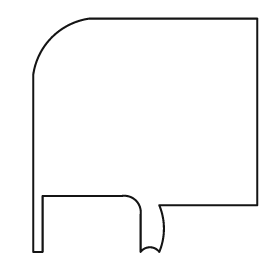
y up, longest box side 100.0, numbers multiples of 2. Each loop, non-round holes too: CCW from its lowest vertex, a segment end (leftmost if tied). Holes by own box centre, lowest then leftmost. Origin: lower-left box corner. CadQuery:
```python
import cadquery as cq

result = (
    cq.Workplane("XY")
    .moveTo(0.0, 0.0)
    .lineTo(4.0, 0.0)
    .lineTo(4.0, 24.0)
    .lineTo(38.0, 24.0)
    .threePointArc((44.0, 22.0), (46.0, 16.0))
    .lineTo(46.0, 0.0)
    .threePointArc((50.0, 2.0), (54.0, 0.0))
    .threePointArc((56.0, 10.0), (54.0, 20.0))
    .lineTo(96.0, 20.0)
    .lineTo(96.0, 100.0)
    .lineTo(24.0, 100.0)
    .threePointArc((8.0, 92.0), (0.0, 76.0))
    .close()
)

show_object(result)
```